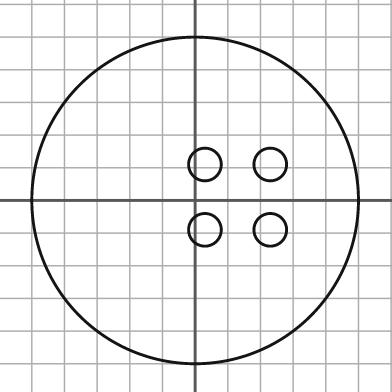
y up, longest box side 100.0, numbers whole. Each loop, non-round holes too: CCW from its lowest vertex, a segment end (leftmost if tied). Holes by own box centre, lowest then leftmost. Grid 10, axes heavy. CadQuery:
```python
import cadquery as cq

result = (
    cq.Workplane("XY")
    .moveTo(0.0, 0.0)
    .circle(50.0)
    .moveTo(3.0, -9.0)
    .circle(5.0)
    .moveTo(23.0, -9.0)
    .circle(5.0)
    .moveTo(3.0, 11.0)
    .circle(5.0)
    .moveTo(23.0, 11.0)
    .circle(5.0)
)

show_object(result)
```